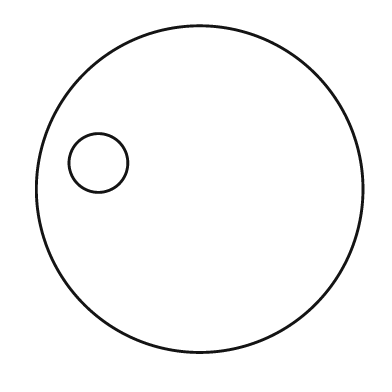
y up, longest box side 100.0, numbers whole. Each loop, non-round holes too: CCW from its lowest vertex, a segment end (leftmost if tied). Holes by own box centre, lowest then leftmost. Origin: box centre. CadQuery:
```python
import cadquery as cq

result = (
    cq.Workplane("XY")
    .moveTo(0.0, 0.0)
    .circle(50.0)
    .moveTo(-31.0, 8.0)
    .circle(9.0)
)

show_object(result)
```